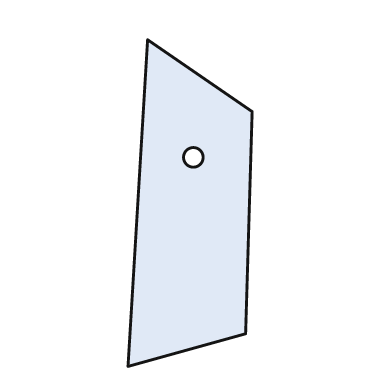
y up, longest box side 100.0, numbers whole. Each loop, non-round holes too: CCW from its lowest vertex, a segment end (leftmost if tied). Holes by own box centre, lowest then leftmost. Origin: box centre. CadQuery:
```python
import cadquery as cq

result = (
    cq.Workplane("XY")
    .moveTo(-19.0, -50.0)
    .lineTo(17.0, -40.0)
    .lineTo(19.0, 28.0)
    .lineTo(-13.0, 50.0)
    .close()
    .moveTo(1.0, 14.0)
    .circle(3.0)
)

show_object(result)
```